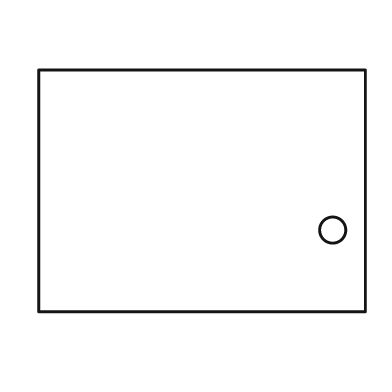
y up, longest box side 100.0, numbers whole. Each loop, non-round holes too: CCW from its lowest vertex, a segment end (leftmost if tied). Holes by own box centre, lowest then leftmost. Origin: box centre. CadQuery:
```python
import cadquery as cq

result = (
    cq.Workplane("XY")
    .moveTo(-50.0, -37.0)
    .lineTo(50.0, -37.0)
    .lineTo(50.0, 37.0)
    .lineTo(-50.0, 37.0)
    .close()
    .moveTo(40.0, -12.0)
    .circle(4.0)
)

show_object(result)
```